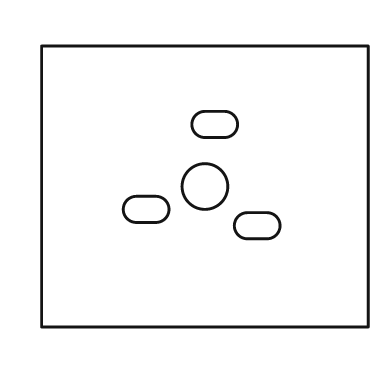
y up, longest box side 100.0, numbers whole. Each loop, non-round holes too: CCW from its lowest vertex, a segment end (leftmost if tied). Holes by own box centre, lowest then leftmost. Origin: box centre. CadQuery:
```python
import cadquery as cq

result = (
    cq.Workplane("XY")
    .moveTo(-50.0, -43.0)
    .lineTo(50.0, -43.0)
    .lineTo(50.0, 43.0)
    .lineTo(-50.0, 43.0)
    .close()
    .moveTo(13.0, -16.0)
    .lineTo(19.0, -16.0)
    .threePointArc((23.0, -12.0), (19.0, -8.0))
    .lineTo(13.0, -8.0)
    .threePointArc((9.0, -12.0), (13.0, -16.0))
    .close()
    .moveTo(-21.0, -11.0)
    .lineTo(-15.0, -11.0)
    .threePointArc((-11.0, -7.0), (-15.0, -3.0))
    .lineTo(-21.0, -3.0)
    .threePointArc((-25.0, -7.0), (-21.0, -11.0))
    .close()
    .moveTo(0.0, 0.0)
    .circle(7.0)
    .moveTo(0.0, 15.0)
    .lineTo(6.0, 15.0)
    .threePointArc((10.0, 19.0), (6.0, 23.0))
    .lineTo(0.0, 23.0)
    .threePointArc((-4.0, 19.0), (0.0, 15.0))
    .close()
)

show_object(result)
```